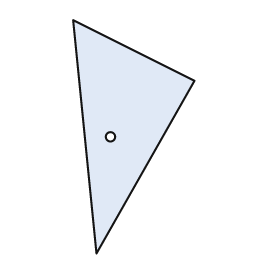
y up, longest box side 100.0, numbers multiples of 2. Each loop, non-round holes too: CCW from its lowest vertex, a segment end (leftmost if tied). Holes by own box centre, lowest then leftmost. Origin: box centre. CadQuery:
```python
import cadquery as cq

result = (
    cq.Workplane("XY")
    .moveTo(-16.0, -50.0)
    .lineTo(26.0, 24.0)
    .lineTo(-26.0, 50.0)
    .close()
    .moveTo(-10.0, 0.0)
    .circle(2.0)
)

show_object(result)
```